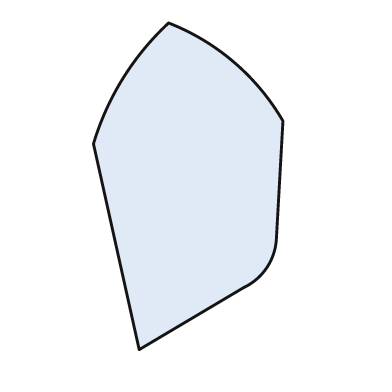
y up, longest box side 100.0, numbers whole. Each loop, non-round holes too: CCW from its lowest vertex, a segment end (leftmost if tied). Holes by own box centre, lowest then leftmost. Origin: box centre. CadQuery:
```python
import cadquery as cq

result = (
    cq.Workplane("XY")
    .moveTo(-15.0, -50.0)
    .lineTo(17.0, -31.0)
    .threePointArc((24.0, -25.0), (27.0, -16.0))
    .lineTo(29.0, 20.0)
    .threePointArc((14.0, 38.0), (-6.0, 50.0))
    .threePointArc((-20.0, 33.0), (-29.0, 13.0))
    .close()
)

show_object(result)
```